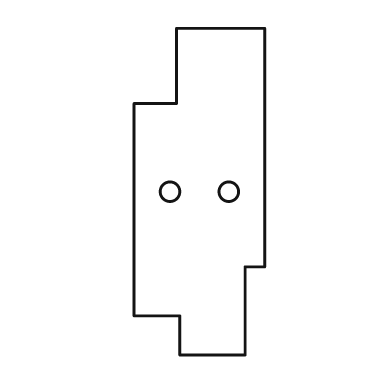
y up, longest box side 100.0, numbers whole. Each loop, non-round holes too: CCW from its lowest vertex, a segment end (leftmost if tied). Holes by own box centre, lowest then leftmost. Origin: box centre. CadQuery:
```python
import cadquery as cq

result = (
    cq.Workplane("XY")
    .moveTo(-6.0, -50.0)
    .lineTo(14.0, -50.0)
    .lineTo(14.0, -23.0)
    .lineTo(20.0, -23.0)
    .lineTo(20.0, 50.0)
    .lineTo(-7.0, 50.0)
    .lineTo(-7.0, 27.0)
    .lineTo(-20.0, 27.0)
    .lineTo(-20.0, -38.0)
    .lineTo(-6.0, -38.0)
    .close()
    .moveTo(-9.0, 0.0)
    .circle(3.0)
    .moveTo(9.0, 0.0)
    .circle(3.0)
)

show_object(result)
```